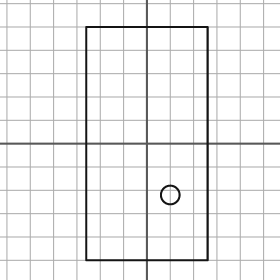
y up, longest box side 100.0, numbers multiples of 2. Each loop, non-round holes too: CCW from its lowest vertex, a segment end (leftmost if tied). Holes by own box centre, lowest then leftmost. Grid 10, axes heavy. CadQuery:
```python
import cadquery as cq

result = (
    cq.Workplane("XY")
    .moveTo(-26.0, -50.0)
    .lineTo(26.0, -50.0)
    .lineTo(26.0, 50.0)
    .lineTo(-26.0, 50.0)
    .close()
    .moveTo(10.0, -22.0)
    .circle(4.0)
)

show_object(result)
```